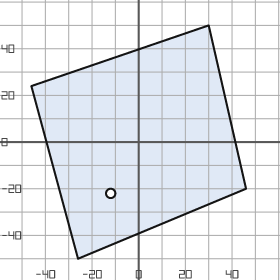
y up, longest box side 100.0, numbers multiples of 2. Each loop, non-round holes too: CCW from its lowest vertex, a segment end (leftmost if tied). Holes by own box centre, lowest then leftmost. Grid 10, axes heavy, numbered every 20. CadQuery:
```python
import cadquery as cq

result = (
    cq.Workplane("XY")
    .moveTo(-26.0, -50.0)
    .lineTo(46.0, -20.0)
    .lineTo(30.0, 50.0)
    .lineTo(-46.0, 24.0)
    .close()
    .moveTo(-12.0, -22.0)
    .circle(2.0)
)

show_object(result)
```